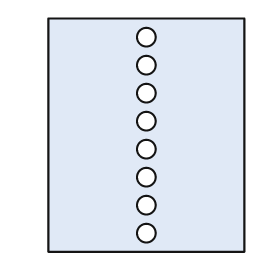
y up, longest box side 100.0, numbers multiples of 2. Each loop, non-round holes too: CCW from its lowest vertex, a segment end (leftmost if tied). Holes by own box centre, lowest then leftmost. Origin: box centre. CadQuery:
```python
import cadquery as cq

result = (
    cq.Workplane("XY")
    .moveTo(-42.0, -50.0)
    .lineTo(42.0, -50.0)
    .lineTo(42.0, 50.0)
    .lineTo(-42.0, 50.0)
    .close()
    .moveTo(0.0, -42.0)
    .circle(4.0)
    .moveTo(0.0, -30.0)
    .circle(4.0)
    .moveTo(0.0, -18.0)
    .circle(4.0)
    .moveTo(0.0, -6.0)
    .circle(4.0)
    .moveTo(0.0, 6.0)
    .circle(4.0)
    .moveTo(0.0, 18.0)
    .circle(4.0)
    .moveTo(0.0, 30.0)
    .circle(4.0)
    .moveTo(0.0, 42.0)
    .circle(4.0)
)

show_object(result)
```